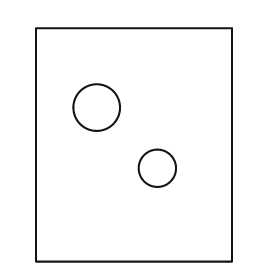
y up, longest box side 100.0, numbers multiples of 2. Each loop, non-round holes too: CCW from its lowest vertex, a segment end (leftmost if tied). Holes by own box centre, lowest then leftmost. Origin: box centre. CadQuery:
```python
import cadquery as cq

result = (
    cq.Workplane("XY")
    .moveTo(-42.0, -50.0)
    .lineTo(42.0, -50.0)
    .lineTo(42.0, 50.0)
    .lineTo(-42.0, 50.0)
    .close()
    .moveTo(10.0, -10.0)
    .circle(8.0)
    .moveTo(-16.0, 16.0)
    .circle(10.0)
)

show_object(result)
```